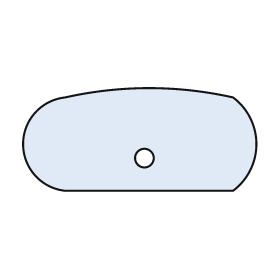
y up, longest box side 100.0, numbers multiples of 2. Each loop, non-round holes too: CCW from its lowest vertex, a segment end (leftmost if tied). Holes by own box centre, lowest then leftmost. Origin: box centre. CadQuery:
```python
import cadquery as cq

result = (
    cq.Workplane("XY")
    .moveTo(-32.0, -22.0)
    .lineTo(40.0, -22.0)
    .threePointArc((50.0, -2.0), (40.0, 18.0))
    .threePointArc((4.0, 22.0), (-32.0, 18.0))
    .threePointArc((-50.0, -2.0), (-32.0, -22.0))
    .close()
    .moveTo(2.0, -8.0)
    .circle(4.0)
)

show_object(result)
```